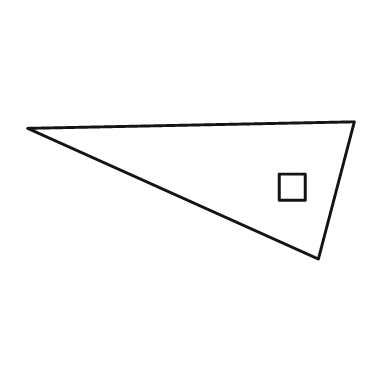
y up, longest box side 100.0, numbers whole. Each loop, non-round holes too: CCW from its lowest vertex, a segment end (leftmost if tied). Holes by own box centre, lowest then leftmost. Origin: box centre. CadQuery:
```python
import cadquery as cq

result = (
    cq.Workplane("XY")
    .moveTo(39.0, -21.0)
    .lineTo(50.0, 21.0)
    .lineTo(-50.0, 19.0)
    .close()
    .moveTo(27.0, -3.0)
    .lineTo(35.0, -3.0)
    .lineTo(35.0, 5.0)
    .lineTo(27.0, 5.0)
    .close()
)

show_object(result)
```